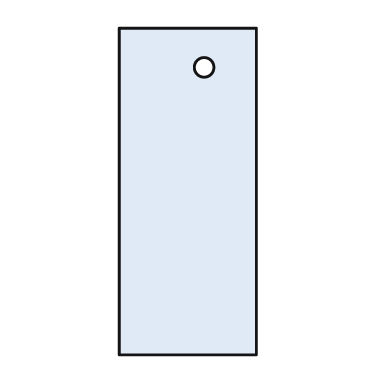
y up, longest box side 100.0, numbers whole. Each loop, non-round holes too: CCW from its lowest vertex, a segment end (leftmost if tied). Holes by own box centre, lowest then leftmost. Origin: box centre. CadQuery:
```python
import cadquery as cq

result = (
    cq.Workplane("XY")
    .moveTo(-21.0, -50.0)
    .lineTo(21.0, -50.0)
    .lineTo(21.0, 50.0)
    .lineTo(-21.0, 50.0)
    .close()
    .moveTo(5.0, 38.0)
    .circle(3.0)
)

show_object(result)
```